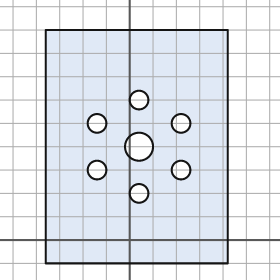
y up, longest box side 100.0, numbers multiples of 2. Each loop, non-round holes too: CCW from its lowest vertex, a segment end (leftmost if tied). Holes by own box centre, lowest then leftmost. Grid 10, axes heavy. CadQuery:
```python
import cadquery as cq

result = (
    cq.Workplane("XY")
    .moveTo(-36.0, -10.0)
    .lineTo(42.0, -10.0)
    .lineTo(42.0, 90.0)
    .lineTo(-36.0, 90.0)
    .close()
    .moveTo(4.0, 20.0)
    .circle(4.0)
    .moveTo(-14.0, 30.0)
    .circle(4.0)
    .moveTo(22.0, 30.0)
    .circle(4.0)
    .moveTo(4.0, 40.0)
    .circle(6.0)
    .moveTo(-14.0, 50.0)
    .circle(4.0)
    .moveTo(22.0, 50.0)
    .circle(4.0)
    .moveTo(4.0, 60.0)
    .circle(4.0)
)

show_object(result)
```